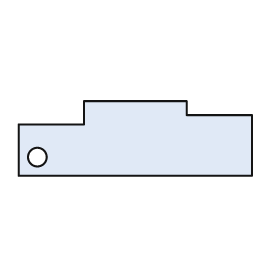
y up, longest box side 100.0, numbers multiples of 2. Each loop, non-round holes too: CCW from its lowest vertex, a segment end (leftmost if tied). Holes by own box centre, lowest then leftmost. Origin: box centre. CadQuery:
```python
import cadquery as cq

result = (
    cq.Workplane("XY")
    .moveTo(-50.0, -16.0)
    .lineTo(50.0, -16.0)
    .lineTo(50.0, 10.0)
    .lineTo(22.0, 10.0)
    .lineTo(22.0, 16.0)
    .lineTo(-22.0, 16.0)
    .lineTo(-22.0, 6.0)
    .lineTo(-50.0, 6.0)
    .close()
    .moveTo(-42.0, -8.0)
    .circle(4.0)
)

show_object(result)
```